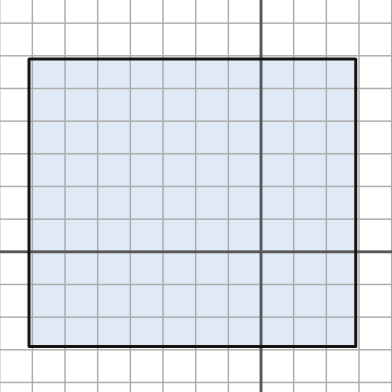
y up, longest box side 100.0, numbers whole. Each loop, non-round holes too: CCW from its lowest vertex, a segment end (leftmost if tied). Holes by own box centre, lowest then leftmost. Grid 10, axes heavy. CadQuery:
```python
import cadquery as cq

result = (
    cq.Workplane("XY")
    .moveTo(-71.0, -29.0)
    .lineTo(29.0, -29.0)
    .lineTo(29.0, 59.0)
    .lineTo(-71.0, 59.0)
    .close()
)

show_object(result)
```